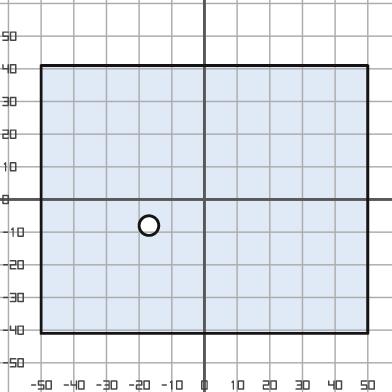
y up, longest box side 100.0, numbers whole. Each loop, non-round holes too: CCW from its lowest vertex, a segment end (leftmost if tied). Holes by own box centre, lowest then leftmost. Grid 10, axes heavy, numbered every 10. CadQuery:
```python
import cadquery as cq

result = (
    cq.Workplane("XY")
    .moveTo(-50.0, -41.0)
    .lineTo(50.0, -41.0)
    .lineTo(50.0, 41.0)
    .lineTo(-50.0, 41.0)
    .close()
    .moveTo(-17.0, -8.0)
    .circle(3.0)
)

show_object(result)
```